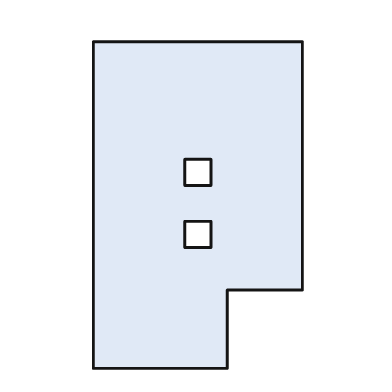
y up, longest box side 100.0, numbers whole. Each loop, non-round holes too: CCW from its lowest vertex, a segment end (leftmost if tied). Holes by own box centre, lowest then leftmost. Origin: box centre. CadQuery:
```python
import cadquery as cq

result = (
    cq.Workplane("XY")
    .moveTo(-32.0, -50.0)
    .lineTo(9.0, -50.0)
    .lineTo(9.0, -26.0)
    .lineTo(32.0, -26.0)
    .lineTo(32.0, 50.0)
    .lineTo(-32.0, 50.0)
    .close()
    .moveTo(-4.0, -13.0)
    .lineTo(4.0, -13.0)
    .lineTo(4.0, -5.0)
    .lineTo(-4.0, -5.0)
    .close()
    .moveTo(-4.0, 6.0)
    .lineTo(4.0, 6.0)
    .lineTo(4.0, 14.0)
    .lineTo(-4.0, 14.0)
    .close()
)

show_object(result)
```